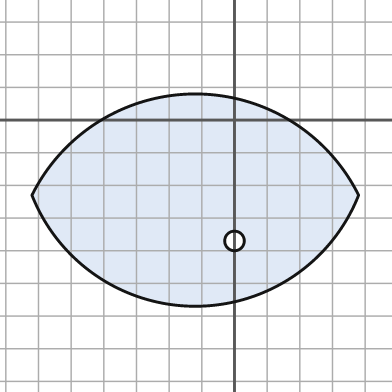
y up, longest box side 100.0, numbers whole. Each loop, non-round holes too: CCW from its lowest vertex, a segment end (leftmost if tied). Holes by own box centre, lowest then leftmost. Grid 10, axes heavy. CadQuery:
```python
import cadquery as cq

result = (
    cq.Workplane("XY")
    .moveTo(-62.0, -23.0)
    .threePointArc((-12.0, -57.0), (38.0, -23.0))
    .threePointArc((-12.0, 8.0), (-62.0, -23.0))
    .close()
    .moveTo(0.0, -37.0)
    .circle(3.0)
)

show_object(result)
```